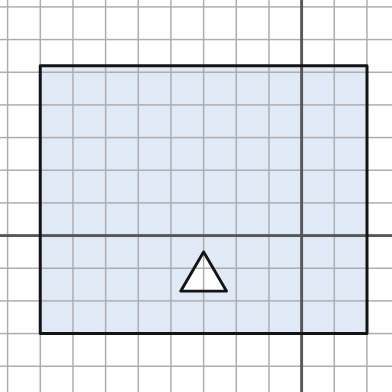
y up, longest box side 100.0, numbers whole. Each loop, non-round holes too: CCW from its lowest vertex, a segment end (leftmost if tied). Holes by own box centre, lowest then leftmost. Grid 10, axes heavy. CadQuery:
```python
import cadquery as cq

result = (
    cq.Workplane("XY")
    .moveTo(-80.0, -30.0)
    .lineTo(20.0, -30.0)
    .lineTo(20.0, 52.0)
    .lineTo(-80.0, 52.0)
    .close()
    .moveTo(-37.0, -17.0)
    .lineTo(-23.0, -17.0)
    .lineTo(-30.0, -5.0)
    .close()
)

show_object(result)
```